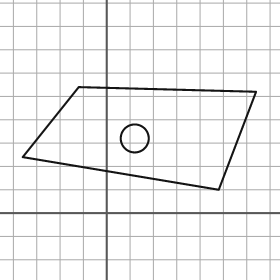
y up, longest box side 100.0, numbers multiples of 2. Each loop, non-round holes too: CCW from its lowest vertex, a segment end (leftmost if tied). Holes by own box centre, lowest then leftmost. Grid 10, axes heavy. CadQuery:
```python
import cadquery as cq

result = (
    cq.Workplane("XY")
    .moveTo(48.0, 10.0)
    .lineTo(64.0, 52.0)
    .lineTo(-12.0, 54.0)
    .lineTo(-36.0, 24.0)
    .close()
    .moveTo(12.0, 32.0)
    .circle(6.0)
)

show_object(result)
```